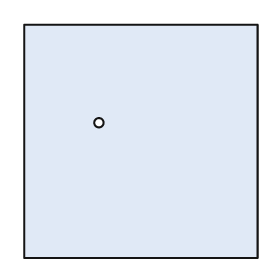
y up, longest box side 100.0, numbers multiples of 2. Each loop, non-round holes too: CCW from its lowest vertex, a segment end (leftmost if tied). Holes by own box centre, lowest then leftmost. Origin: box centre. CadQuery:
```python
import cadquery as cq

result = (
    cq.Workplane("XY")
    .moveTo(-50.0, -50.0)
    .lineTo(50.0, -50.0)
    .lineTo(50.0, 50.0)
    .lineTo(-50.0, 50.0)
    .close()
    .moveTo(-18.0, 8.0)
    .circle(2.0)
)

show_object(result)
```